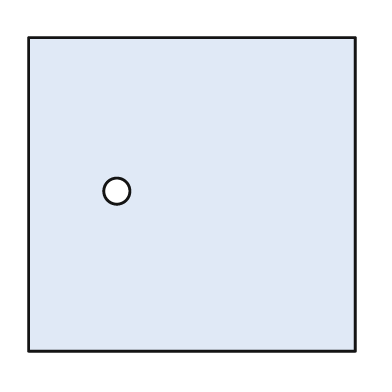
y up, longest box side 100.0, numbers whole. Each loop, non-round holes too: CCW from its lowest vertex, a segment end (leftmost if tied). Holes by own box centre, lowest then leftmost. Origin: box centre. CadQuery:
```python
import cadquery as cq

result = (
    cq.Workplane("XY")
    .moveTo(-50.0, -48.0)
    .lineTo(50.0, -48.0)
    .lineTo(50.0, 48.0)
    .lineTo(-50.0, 48.0)
    .close()
    .moveTo(-23.0, 1.0)
    .circle(4.0)
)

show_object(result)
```